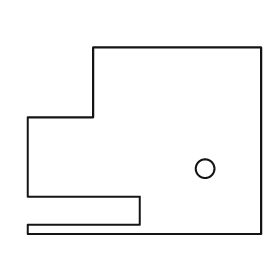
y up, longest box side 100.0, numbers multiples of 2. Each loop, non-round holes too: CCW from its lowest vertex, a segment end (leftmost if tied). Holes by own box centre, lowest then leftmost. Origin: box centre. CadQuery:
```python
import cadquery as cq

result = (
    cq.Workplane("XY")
    .moveTo(-50.0, -40.0)
    .lineTo(50.0, -40.0)
    .lineTo(50.0, 40.0)
    .lineTo(-22.0, 40.0)
    .lineTo(-22.0, 10.0)
    .lineTo(-50.0, 10.0)
    .lineTo(-50.0, -24.0)
    .lineTo(-2.0, -24.0)
    .lineTo(-2.0, -36.0)
    .lineTo(-50.0, -36.0)
    .close()
    .moveTo(26.0, -12.0)
    .circle(4.0)
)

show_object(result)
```